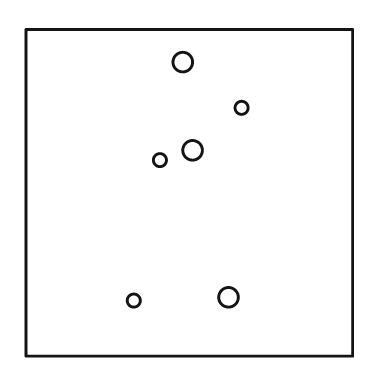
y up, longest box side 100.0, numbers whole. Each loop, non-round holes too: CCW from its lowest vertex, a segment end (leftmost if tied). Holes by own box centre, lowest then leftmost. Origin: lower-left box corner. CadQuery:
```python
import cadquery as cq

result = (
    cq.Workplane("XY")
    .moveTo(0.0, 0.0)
    .lineTo(100.0, 0.0)
    .lineTo(100.0, 100.0)
    .lineTo(0.0, 100.0)
    .close()
    .moveTo(33.0, 17.0)
    .circle(2.0)
    .moveTo(62.0, 18.0)
    .circle(3.0)
    .moveTo(41.0, 60.0)
    .circle(2.0)
    .moveTo(51.0, 63.0)
    .circle(3.0)
    .moveTo(66.0, 76.0)
    .circle(2.0)
    .moveTo(48.0, 90.0)
    .circle(3.0)
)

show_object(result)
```